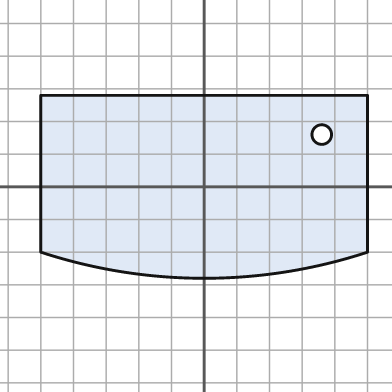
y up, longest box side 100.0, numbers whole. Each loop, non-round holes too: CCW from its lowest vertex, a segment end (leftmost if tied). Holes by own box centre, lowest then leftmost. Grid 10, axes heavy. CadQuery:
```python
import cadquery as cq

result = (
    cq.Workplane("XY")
    .moveTo(-50.0, -20.0)
    .threePointArc((0.0, -28.0), (50.0, -20.0))
    .lineTo(50.0, 28.0)
    .lineTo(-50.0, 28.0)
    .close()
    .moveTo(36.0, 16.0)
    .circle(3.0)
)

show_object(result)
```